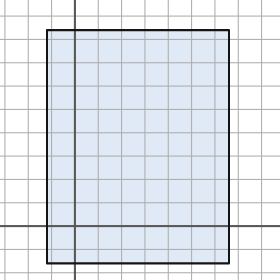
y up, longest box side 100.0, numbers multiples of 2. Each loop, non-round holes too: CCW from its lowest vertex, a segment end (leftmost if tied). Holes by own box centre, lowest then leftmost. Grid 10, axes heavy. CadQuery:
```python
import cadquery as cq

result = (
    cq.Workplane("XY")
    .moveTo(-12.0, -16.0)
    .lineTo(66.0, -16.0)
    .lineTo(66.0, 84.0)
    .lineTo(-12.0, 84.0)
    .close()
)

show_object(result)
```